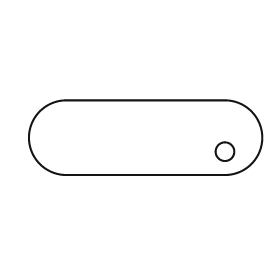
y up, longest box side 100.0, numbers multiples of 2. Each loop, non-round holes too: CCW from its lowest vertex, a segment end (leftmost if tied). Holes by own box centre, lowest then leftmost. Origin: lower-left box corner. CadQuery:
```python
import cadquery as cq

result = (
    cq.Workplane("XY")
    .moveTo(16.0, 0.0)
    .lineTo(84.0, 0.0)
    .threePointArc((100.0, 16.0), (84.0, 32.0))
    .lineTo(16.0, 32.0)
    .threePointArc((0.0, 16.0), (16.0, 0.0))
    .close()
    .moveTo(84.0, 10.0)
    .circle(4.0)
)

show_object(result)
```